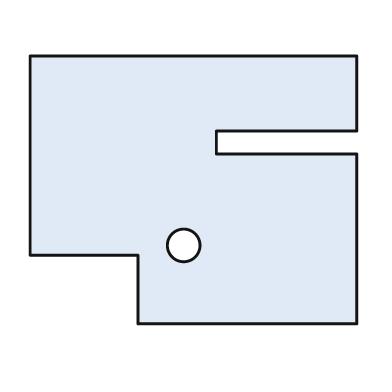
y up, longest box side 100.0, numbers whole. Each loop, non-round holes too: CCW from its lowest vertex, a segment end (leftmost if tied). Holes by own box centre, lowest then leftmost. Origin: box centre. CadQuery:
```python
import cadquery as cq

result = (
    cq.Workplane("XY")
    .moveTo(-17.0, -41.0)
    .lineTo(50.0, -41.0)
    .lineTo(50.0, 11.0)
    .lineTo(7.0, 11.0)
    .lineTo(7.0, 18.0)
    .lineTo(50.0, 18.0)
    .lineTo(50.0, 41.0)
    .lineTo(-50.0, 41.0)
    .lineTo(-50.0, -20.0)
    .lineTo(-17.0, -20.0)
    .close()
    .moveTo(-3.0, -17.0)
    .circle(5.0)
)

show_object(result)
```